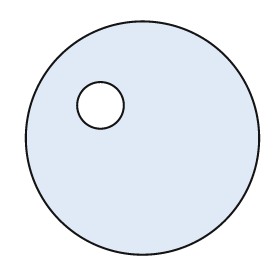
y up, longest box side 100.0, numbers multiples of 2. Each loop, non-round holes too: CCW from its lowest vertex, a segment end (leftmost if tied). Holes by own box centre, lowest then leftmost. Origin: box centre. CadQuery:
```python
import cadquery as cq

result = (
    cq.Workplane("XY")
    .moveTo(0.0, 0.0)
    .circle(50.0)
    .moveTo(-18.0, 14.0)
    .circle(10.0)
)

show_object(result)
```